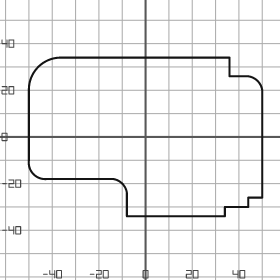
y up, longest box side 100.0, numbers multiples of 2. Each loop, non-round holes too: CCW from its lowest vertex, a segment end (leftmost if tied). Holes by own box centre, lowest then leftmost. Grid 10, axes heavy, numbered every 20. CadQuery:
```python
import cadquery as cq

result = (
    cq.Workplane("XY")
    .moveTo(-8.0, -34.0)
    .lineTo(34.0, -34.0)
    .lineTo(34.0, -30.0)
    .lineTo(44.0, -30.0)
    .lineTo(44.0, -26.0)
    .lineTo(50.0, -26.0)
    .lineTo(50.0, 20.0)
    .threePointArc((48.0, 24.0), (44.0, 26.0))
    .lineTo(36.0, 26.0)
    .lineTo(36.0, 34.0)
    .lineTo(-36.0, 34.0)
    .threePointArc((-46.0, 30.0), (-50.0, 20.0))
    .lineTo(-50.0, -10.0)
    .threePointArc((-48.0, -16.0), (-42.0, -18.0))
    .lineTo(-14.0, -18.0)
    .threePointArc((-10.0, -20.0), (-8.0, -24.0))
    .close()
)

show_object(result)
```